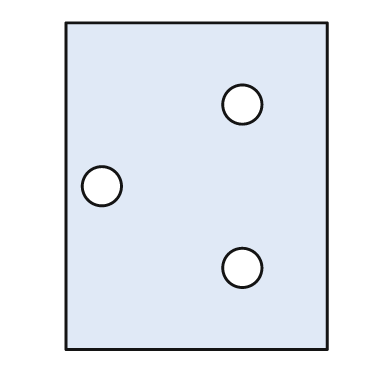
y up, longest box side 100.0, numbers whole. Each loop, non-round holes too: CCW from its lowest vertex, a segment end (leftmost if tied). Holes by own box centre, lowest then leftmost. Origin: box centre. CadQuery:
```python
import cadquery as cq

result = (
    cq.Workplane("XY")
    .moveTo(-40.0, -50.0)
    .lineTo(40.0, -50.0)
    .lineTo(40.0, 50.0)
    .lineTo(-40.0, 50.0)
    .close()
    .moveTo(14.0, -25.0)
    .circle(6.0)
    .moveTo(-29.0, 0.0)
    .circle(6.0)
    .moveTo(14.0, 25.0)
    .circle(6.0)
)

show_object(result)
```